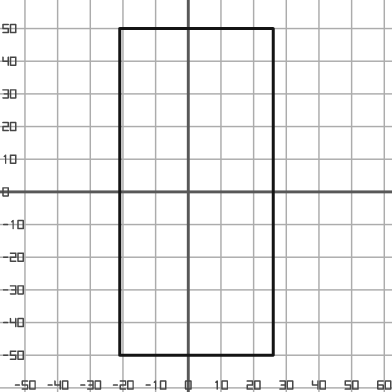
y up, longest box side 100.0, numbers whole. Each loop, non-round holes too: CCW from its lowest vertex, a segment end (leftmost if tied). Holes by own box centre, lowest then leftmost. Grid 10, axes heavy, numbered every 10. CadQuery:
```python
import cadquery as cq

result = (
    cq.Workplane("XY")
    .moveTo(-21.0, -50.0)
    .lineTo(26.0, -50.0)
    .lineTo(26.0, 50.0)
    .lineTo(-21.0, 50.0)
    .close()
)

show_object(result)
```